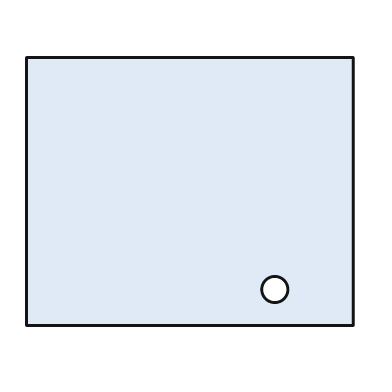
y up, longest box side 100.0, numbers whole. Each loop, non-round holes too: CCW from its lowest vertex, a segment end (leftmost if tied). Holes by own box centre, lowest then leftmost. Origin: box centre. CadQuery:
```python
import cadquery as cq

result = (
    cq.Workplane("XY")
    .moveTo(-50.0, -41.0)
    .lineTo(50.0, -41.0)
    .lineTo(50.0, 41.0)
    .lineTo(-50.0, 41.0)
    .close()
    .moveTo(26.0, -30.0)
    .circle(4.0)
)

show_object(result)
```